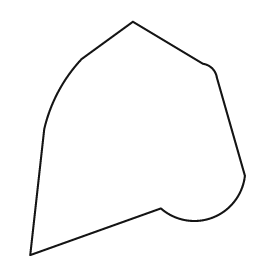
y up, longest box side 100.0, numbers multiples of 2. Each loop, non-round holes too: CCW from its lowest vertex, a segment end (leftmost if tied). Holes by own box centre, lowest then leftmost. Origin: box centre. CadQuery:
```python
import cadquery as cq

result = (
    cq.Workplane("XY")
    .moveTo(-46.0, -50.0)
    .lineTo(10.0, -30.0)
    .threePointArc((32.0, -34.0), (46.0, -16.0))
    .lineTo(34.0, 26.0)
    .threePointArc((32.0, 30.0), (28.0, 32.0))
    .lineTo(-2.0, 50.0)
    .lineTo(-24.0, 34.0)
    .threePointArc((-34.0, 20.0), (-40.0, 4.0))
    .close()
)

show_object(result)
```